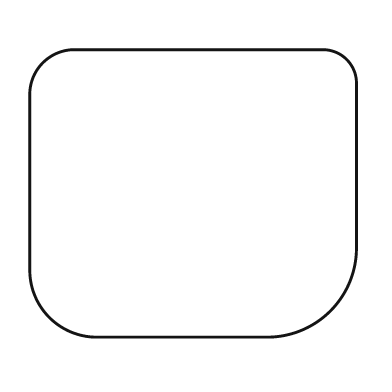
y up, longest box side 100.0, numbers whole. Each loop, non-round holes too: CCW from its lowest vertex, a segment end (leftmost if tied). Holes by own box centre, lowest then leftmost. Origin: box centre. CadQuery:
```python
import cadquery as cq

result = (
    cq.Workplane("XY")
    .moveTo(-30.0, -44.0)
    .lineTo(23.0, -44.0)
    .threePointArc((42.0, -36.0), (50.0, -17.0))
    .lineTo(50.0, 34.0)
    .threePointArc((47.0, 41.0), (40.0, 44.0))
    .lineTo(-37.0, 44.0)
    .threePointArc((-46.0, 40.0), (-50.0, 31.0))
    .lineTo(-50.0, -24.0)
    .threePointArc((-44.0, -38.0), (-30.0, -44.0))
    .close()
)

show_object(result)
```